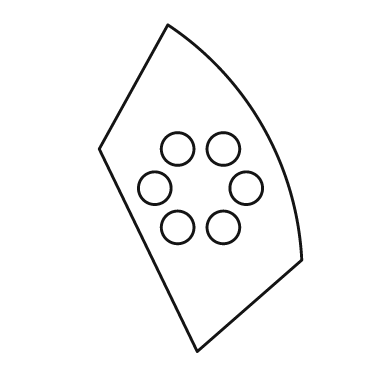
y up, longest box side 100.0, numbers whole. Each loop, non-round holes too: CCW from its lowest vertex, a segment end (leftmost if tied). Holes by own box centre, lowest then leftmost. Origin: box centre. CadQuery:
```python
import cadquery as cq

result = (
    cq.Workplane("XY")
    .moveTo(-1.0, -50.0)
    .lineTo(31.0, -22.0)
    .threePointArc((19.0, 19.0), (-10.0, 50.0))
    .lineTo(-31.0, 12.0)
    .close()
    .moveTo(-7.0, -12.0)
    .circle(5.0)
    .moveTo(7.0, -12.0)
    .circle(5.0)
    .moveTo(-14.0, 0.0)
    .circle(5.0)
    .moveTo(14.0, 0.0)
    .circle(5.0)
    .moveTo(-7.0, 12.0)
    .circle(5.0)
    .moveTo(7.0, 12.0)
    .circle(5.0)
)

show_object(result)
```